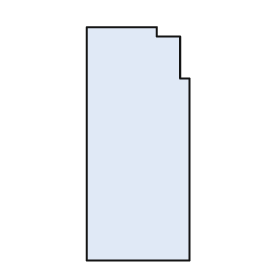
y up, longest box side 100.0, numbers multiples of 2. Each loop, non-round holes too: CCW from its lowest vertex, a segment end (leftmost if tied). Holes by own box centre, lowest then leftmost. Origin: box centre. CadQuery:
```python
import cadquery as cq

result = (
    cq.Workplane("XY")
    .moveTo(-22.0, -50.0)
    .lineTo(22.0, -50.0)
    .lineTo(22.0, 28.0)
    .lineTo(18.0, 28.0)
    .lineTo(18.0, 46.0)
    .lineTo(8.0, 46.0)
    .lineTo(8.0, 50.0)
    .lineTo(-22.0, 50.0)
    .close()
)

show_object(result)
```